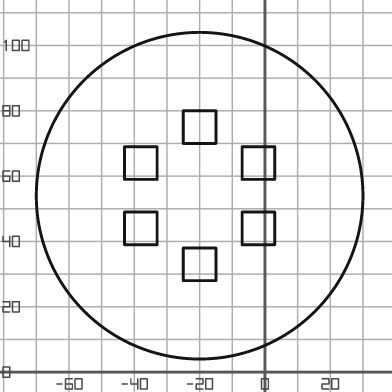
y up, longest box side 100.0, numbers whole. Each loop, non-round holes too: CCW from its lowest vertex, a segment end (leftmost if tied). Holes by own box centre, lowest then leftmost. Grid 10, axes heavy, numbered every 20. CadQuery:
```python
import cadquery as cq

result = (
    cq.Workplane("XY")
    .moveTo(-20.0, 54.0)
    .circle(50.0)
    .moveTo(-25.0, 28.0)
    .lineTo(-15.0, 28.0)
    .lineTo(-15.0, 38.0)
    .lineTo(-25.0, 38.0)
    .close()
    .moveTo(-43.0, 39.0)
    .lineTo(-33.0, 39.0)
    .lineTo(-33.0, 49.0)
    .lineTo(-43.0, 49.0)
    .close()
    .moveTo(-7.0, 39.0)
    .lineTo(3.0, 39.0)
    .lineTo(3.0, 49.0)
    .lineTo(-7.0, 49.0)
    .close()
    .moveTo(-43.0, 59.0)
    .lineTo(-33.0, 59.0)
    .lineTo(-33.0, 69.0)
    .lineTo(-43.0, 69.0)
    .close()
    .moveTo(-7.0, 59.0)
    .lineTo(3.0, 59.0)
    .lineTo(3.0, 69.0)
    .lineTo(-7.0, 69.0)
    .close()
    .moveTo(-25.0, 70.0)
    .lineTo(-15.0, 70.0)
    .lineTo(-15.0, 80.0)
    .lineTo(-25.0, 80.0)
    .close()
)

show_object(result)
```